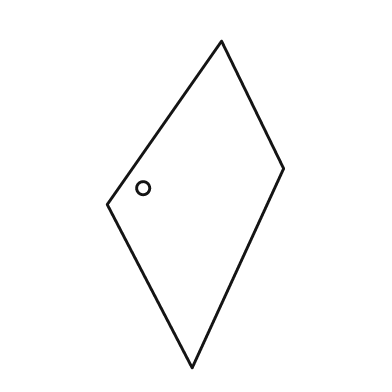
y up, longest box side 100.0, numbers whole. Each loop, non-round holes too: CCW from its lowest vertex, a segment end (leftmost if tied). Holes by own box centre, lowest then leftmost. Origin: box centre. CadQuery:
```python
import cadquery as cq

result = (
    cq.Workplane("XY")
    .moveTo(-1.0, -50.0)
    .lineTo(27.0, 11.0)
    .lineTo(8.0, 50.0)
    .lineTo(-27.0, 0.0)
    .close()
    .moveTo(-16.0, 5.0)
    .circle(2.0)
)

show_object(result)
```